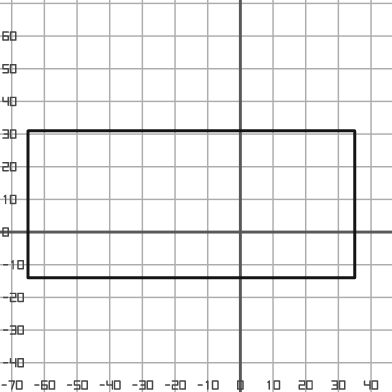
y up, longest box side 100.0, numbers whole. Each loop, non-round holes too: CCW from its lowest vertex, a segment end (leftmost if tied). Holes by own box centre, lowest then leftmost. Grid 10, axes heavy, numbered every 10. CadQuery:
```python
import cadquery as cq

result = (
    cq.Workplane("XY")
    .moveTo(-65.0, -14.0)
    .lineTo(35.0, -14.0)
    .lineTo(35.0, 31.0)
    .lineTo(-65.0, 31.0)
    .close()
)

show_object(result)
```